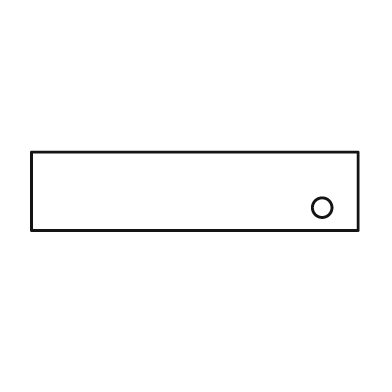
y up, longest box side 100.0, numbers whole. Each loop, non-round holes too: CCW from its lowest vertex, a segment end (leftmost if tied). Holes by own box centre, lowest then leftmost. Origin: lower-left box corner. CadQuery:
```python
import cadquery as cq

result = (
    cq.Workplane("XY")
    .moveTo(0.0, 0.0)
    .lineTo(100.0, 0.0)
    .lineTo(100.0, 24.0)
    .lineTo(0.0, 24.0)
    .close()
    .moveTo(89.0, 7.0)
    .circle(3.0)
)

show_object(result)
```